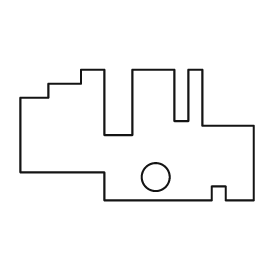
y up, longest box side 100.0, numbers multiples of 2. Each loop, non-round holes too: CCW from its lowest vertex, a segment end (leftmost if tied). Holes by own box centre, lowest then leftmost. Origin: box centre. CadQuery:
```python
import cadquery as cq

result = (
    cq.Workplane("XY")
    .moveTo(-14.0, -28.0)
    .lineTo(32.0, -28.0)
    .lineTo(32.0, -22.0)
    .lineTo(38.0, -22.0)
    .lineTo(38.0, -28.0)
    .lineTo(50.0, -28.0)
    .lineTo(50.0, 4.0)
    .lineTo(28.0, 4.0)
    .lineTo(28.0, 28.0)
    .lineTo(22.0, 28.0)
    .lineTo(22.0, 6.0)
    .lineTo(16.0, 6.0)
    .lineTo(16.0, 28.0)
    .lineTo(-2.0, 28.0)
    .lineTo(-2.0, 0.0)
    .lineTo(-14.0, 0.0)
    .lineTo(-14.0, 28.0)
    .lineTo(-24.0, 28.0)
    .lineTo(-24.0, 22.0)
    .lineTo(-38.0, 22.0)
    .lineTo(-38.0, 16.0)
    .lineTo(-50.0, 16.0)
    .lineTo(-50.0, -16.0)
    .lineTo(-14.0, -16.0)
    .close()
    .moveTo(8.0, -18.0)
    .circle(6.0)
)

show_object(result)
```